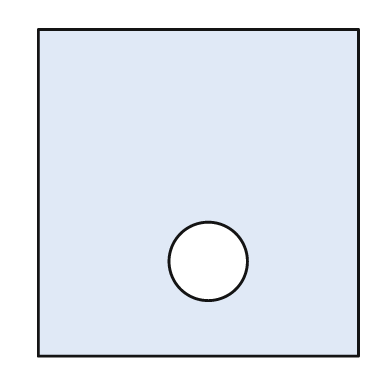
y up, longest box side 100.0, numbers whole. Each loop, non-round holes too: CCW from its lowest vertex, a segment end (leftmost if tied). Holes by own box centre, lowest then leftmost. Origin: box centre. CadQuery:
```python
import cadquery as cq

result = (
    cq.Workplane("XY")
    .moveTo(-49.0, -50.0)
    .lineTo(49.0, -50.0)
    .lineTo(49.0, 50.0)
    .lineTo(-49.0, 50.0)
    .close()
    .moveTo(3.0, -21.0)
    .circle(12.0)
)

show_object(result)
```